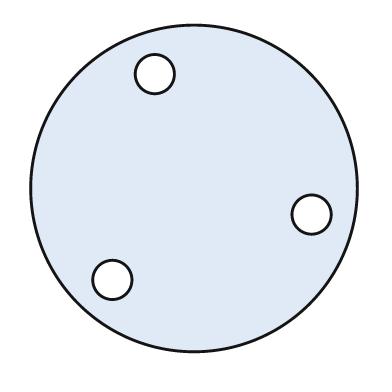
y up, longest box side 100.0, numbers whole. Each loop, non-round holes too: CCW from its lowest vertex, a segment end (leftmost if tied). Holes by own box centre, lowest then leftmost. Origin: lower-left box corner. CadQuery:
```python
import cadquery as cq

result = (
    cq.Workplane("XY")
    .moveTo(50.0, 50.0)
    .circle(50.0)
    .moveTo(25.0, 22.0)
    .circle(6.0)
    .moveTo(86.0, 42.0)
    .circle(6.0)
    .moveTo(38.0, 85.0)
    .circle(6.0)
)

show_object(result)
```